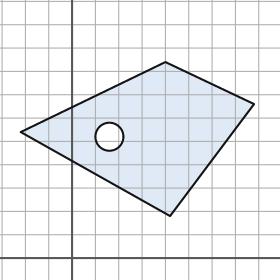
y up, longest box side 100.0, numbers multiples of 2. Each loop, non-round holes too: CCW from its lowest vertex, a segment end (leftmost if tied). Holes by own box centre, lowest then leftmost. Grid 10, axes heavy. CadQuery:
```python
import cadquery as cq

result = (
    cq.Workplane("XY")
    .moveTo(42.0, 18.0)
    .lineTo(78.0, 66.0)
    .lineTo(40.0, 84.0)
    .lineTo(-22.0, 54.0)
    .close()
    .moveTo(16.0, 52.0)
    .circle(6.0)
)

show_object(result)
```